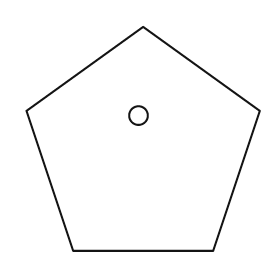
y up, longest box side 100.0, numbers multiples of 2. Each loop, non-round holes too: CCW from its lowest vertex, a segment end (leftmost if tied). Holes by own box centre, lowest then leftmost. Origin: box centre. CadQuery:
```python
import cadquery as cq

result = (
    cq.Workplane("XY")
    .moveTo(-30.0, -48.0)
    .lineTo(30.0, -48.0)
    .lineTo(50.0, 12.0)
    .lineTo(0.0, 48.0)
    .lineTo(-50.0, 12.0)
    .close()
    .moveTo(-2.0, 10.0)
    .circle(4.0)
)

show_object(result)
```